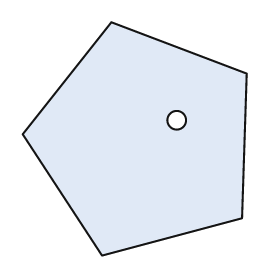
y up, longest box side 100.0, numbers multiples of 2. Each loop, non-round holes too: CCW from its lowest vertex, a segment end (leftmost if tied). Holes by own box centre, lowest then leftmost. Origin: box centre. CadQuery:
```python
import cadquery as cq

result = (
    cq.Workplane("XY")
    .moveTo(-14.0, -50.0)
    .lineTo(46.0, -34.0)
    .lineTo(48.0, 28.0)
    .lineTo(-10.0, 50.0)
    .lineTo(-48.0, 2.0)
    .close()
    .moveTo(18.0, 8.0)
    .circle(4.0)
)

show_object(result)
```